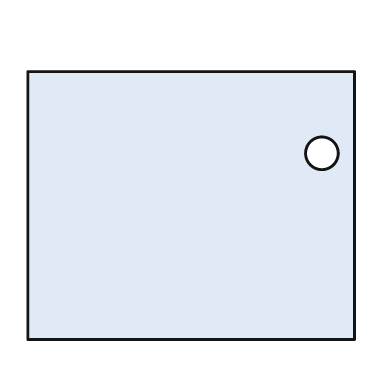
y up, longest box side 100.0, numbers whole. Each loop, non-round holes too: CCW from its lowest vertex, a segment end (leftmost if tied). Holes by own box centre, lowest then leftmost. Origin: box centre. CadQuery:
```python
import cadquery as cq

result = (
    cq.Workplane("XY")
    .moveTo(-50.0, -41.0)
    .lineTo(50.0, -41.0)
    .lineTo(50.0, 41.0)
    .lineTo(-50.0, 41.0)
    .close()
    .moveTo(40.0, 16.0)
    .circle(5.0)
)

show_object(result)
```